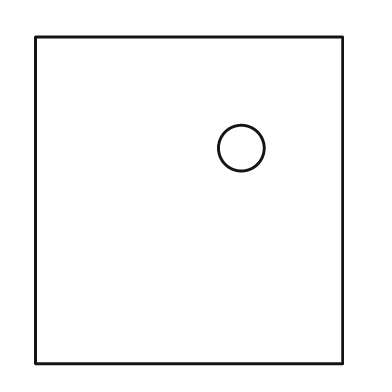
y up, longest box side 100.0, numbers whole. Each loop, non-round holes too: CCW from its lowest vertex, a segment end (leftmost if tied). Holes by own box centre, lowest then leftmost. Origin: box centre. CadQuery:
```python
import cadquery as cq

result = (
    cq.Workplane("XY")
    .moveTo(-47.0, -50.0)
    .lineTo(47.0, -50.0)
    .lineTo(47.0, 50.0)
    .lineTo(-47.0, 50.0)
    .close()
    .moveTo(16.0, 16.0)
    .circle(7.0)
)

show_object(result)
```